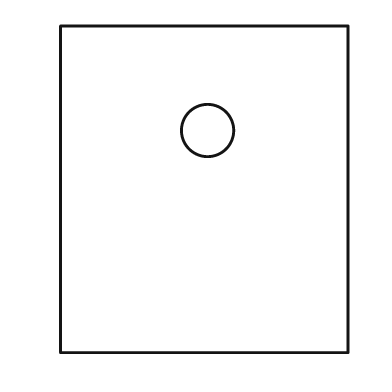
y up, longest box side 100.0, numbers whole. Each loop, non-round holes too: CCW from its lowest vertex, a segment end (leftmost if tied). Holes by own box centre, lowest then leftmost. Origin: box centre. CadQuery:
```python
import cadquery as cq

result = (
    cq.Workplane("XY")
    .moveTo(-44.0, -50.0)
    .lineTo(44.0, -50.0)
    .lineTo(44.0, 50.0)
    .lineTo(-44.0, 50.0)
    .close()
    .moveTo(1.0, 18.0)
    .circle(8.0)
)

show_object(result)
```